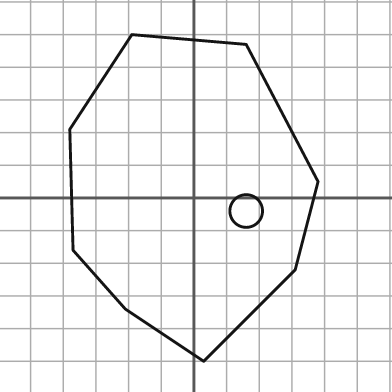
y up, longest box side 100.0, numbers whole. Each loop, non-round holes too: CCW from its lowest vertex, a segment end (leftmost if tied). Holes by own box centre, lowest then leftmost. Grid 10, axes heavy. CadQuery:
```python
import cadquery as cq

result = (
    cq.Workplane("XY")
    .moveTo(3.0, -50.0)
    .lineTo(31.0, -22.0)
    .lineTo(38.0, 5.0)
    .lineTo(16.0, 47.0)
    .lineTo(-19.0, 50.0)
    .lineTo(-38.0, 21.0)
    .lineTo(-37.0, -16.0)
    .lineTo(-21.0, -34.0)
    .close()
    .moveTo(16.0, -4.0)
    .circle(5.0)
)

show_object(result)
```